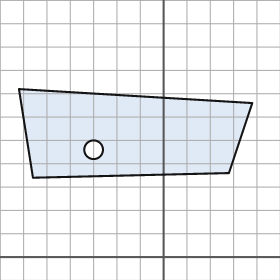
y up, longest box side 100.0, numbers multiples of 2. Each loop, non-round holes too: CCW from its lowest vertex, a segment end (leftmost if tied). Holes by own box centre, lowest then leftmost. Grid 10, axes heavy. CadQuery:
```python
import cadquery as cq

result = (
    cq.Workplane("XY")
    .moveTo(-56.0, 34.0)
    .lineTo(28.0, 36.0)
    .lineTo(38.0, 66.0)
    .lineTo(-62.0, 72.0)
    .close()
    .moveTo(-30.0, 46.0)
    .circle(4.0)
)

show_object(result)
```